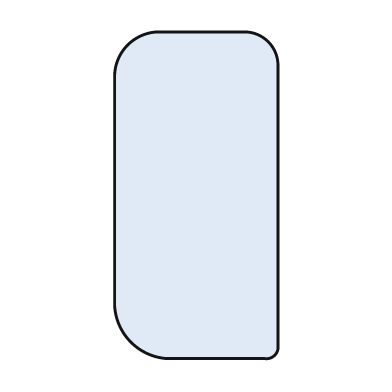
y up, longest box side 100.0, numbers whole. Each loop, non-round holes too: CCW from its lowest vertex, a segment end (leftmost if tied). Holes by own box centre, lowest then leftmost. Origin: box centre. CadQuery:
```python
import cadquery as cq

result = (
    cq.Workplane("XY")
    .moveTo(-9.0, -50.0)
    .lineTo(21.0, -50.0)
    .threePointArc((24.0, -49.0), (25.0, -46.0))
    .lineTo(25.0, 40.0)
    .threePointArc((22.0, 47.0), (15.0, 50.0))
    .lineTo(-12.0, 50.0)
    .threePointArc((-21.0, 46.0), (-25.0, 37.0))
    .lineTo(-25.0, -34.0)
    .threePointArc((-20.0, -45.0), (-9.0, -50.0))
    .close()
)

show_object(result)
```